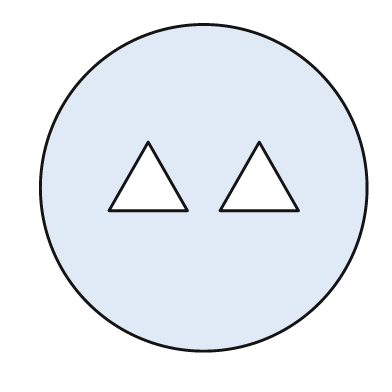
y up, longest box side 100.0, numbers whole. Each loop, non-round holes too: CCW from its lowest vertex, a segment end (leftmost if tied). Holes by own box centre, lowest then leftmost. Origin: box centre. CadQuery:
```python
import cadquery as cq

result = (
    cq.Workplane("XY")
    .moveTo(0.0, 0.0)
    .circle(50.0)
    .moveTo(-29.0, -7.0)
    .lineTo(-5.0, -7.0)
    .lineTo(-17.0, 14.0)
    .close()
    .moveTo(5.0, -7.0)
    .lineTo(29.0, -7.0)
    .lineTo(17.0, 14.0)
    .close()
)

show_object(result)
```